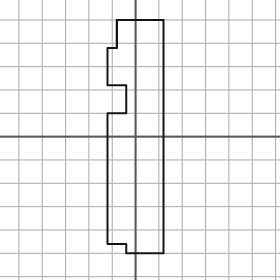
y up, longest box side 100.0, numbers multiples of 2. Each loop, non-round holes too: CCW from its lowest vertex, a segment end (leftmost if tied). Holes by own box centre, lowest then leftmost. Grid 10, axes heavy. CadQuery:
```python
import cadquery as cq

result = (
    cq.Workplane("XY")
    .moveTo(-4.0, -50.0)
    .lineTo(12.0, -50.0)
    .lineTo(12.0, 50.0)
    .lineTo(-8.0, 50.0)
    .lineTo(-8.0, 38.0)
    .lineTo(-12.0, 38.0)
    .lineTo(-12.0, 22.0)
    .lineTo(-4.0, 22.0)
    .lineTo(-4.0, 10.0)
    .lineTo(-12.0, 10.0)
    .lineTo(-12.0, -46.0)
    .lineTo(-4.0, -46.0)
    .close()
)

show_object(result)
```